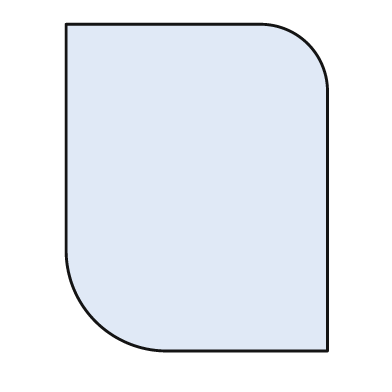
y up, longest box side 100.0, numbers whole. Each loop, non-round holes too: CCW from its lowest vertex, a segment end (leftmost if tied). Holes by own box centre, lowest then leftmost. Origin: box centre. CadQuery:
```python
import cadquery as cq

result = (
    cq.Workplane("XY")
    .moveTo(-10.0, -50.0)
    .lineTo(40.0, -50.0)
    .lineTo(40.0, 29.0)
    .threePointArc((34.0, 44.0), (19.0, 50.0))
    .lineTo(-40.0, 50.0)
    .lineTo(-40.0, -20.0)
    .threePointArc((-31.0, -41.0), (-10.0, -50.0))
    .close()
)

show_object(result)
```